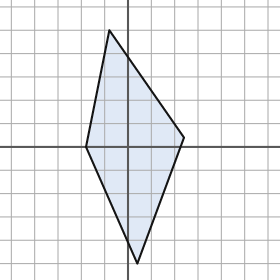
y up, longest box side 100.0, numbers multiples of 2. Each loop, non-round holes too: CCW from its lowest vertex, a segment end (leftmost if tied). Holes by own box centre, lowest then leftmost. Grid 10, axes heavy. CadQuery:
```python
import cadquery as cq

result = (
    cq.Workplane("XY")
    .moveTo(4.0, -50.0)
    .lineTo(24.0, 4.0)
    .lineTo(-8.0, 50.0)
    .lineTo(-18.0, 0.0)
    .close()
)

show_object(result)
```